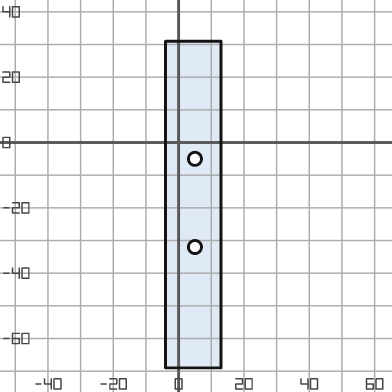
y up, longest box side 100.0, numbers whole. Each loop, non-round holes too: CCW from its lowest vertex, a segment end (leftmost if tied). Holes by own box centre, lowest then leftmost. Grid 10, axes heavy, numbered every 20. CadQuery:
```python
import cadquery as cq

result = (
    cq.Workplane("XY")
    .moveTo(-4.0, -69.0)
    .lineTo(13.0, -69.0)
    .lineTo(13.0, 31.0)
    .lineTo(-4.0, 31.0)
    .close()
    .moveTo(5.0, -32.0)
    .circle(2.0)
    .moveTo(5.0, -5.0)
    .circle(2.0)
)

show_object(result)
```